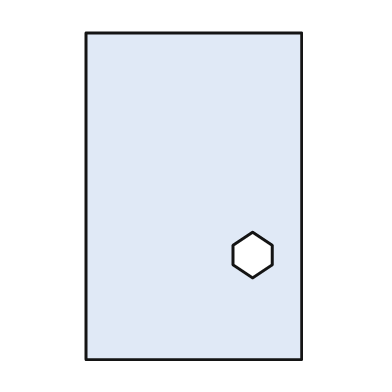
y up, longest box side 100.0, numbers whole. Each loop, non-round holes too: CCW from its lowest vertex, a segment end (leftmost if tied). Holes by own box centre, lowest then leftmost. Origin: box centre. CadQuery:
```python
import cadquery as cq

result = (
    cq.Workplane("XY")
    .moveTo(-33.0, -50.0)
    .lineTo(33.0, -50.0)
    .lineTo(33.0, 50.0)
    .lineTo(-33.0, 50.0)
    .close()
    .moveTo(18.0, -25.0)
    .lineTo(24.0, -21.0)
    .lineTo(24.0, -15.0)
    .lineTo(18.0, -11.0)
    .lineTo(12.0, -15.0)
    .lineTo(12.0, -21.0)
    .close()
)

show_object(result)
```